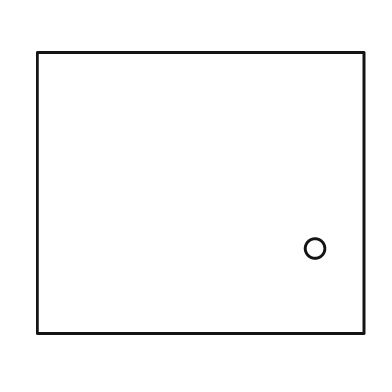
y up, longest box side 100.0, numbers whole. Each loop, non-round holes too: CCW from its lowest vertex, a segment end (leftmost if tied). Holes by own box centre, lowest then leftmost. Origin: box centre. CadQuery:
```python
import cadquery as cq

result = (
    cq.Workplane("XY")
    .moveTo(-50.0, -43.0)
    .lineTo(50.0, -43.0)
    .lineTo(50.0, 43.0)
    .lineTo(-50.0, 43.0)
    .close()
    .moveTo(35.0, -17.0)
    .circle(3.0)
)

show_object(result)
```